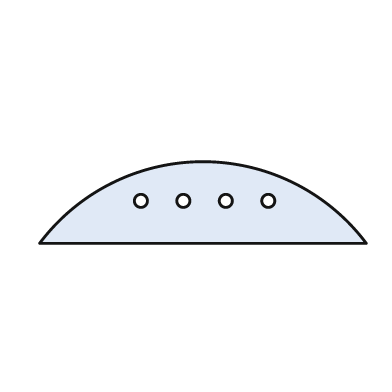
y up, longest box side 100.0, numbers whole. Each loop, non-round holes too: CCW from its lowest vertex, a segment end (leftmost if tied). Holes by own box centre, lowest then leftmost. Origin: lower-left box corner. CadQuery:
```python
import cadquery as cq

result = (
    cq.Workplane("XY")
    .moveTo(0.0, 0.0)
    .lineTo(100.0, 0.0)
    .threePointArc((50.0, 25.0), (0.0, 0.0))
    .close()
    .moveTo(31.0, 13.0)
    .circle(2.0)
    .moveTo(44.0, 13.0)
    .circle(2.0)
    .moveTo(57.0, 13.0)
    .circle(2.0)
    .moveTo(70.0, 13.0)
    .circle(2.0)
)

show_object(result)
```